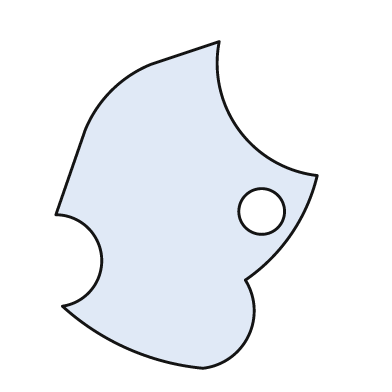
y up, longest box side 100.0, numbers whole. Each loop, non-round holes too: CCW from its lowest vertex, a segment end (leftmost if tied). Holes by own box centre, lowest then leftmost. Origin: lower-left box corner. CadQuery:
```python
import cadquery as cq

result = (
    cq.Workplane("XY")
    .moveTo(45.0, 0.0)
    .threePointArc((59.0, 10.0), (58.0, 27.0))
    .threePointArc((72.0, 41.0), (80.0, 59.0))
    .threePointArc((56.0, 73.0), (50.0, 100.0))
    .lineTo(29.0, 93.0)
    .threePointArc((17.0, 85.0), (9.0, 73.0))
    .lineTo(0.0, 47.0)
    .threePointArc((14.0, 34.0), (2.0, 19.0))
    .threePointArc((22.0, 6.0), (45.0, 0.0))
    .close()
    .moveTo(63.0, 48.0)
    .circle(7.0)
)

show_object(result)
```